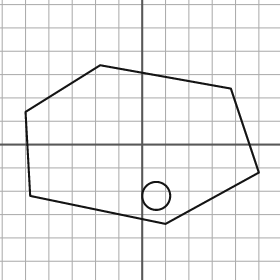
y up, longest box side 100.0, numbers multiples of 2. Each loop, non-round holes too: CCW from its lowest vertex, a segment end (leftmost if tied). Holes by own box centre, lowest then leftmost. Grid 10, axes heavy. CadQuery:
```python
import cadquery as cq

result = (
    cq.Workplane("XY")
    .moveTo(10.0, -34.0)
    .lineTo(50.0, -12.0)
    .lineTo(38.0, 24.0)
    .lineTo(-18.0, 34.0)
    .lineTo(-50.0, 14.0)
    .lineTo(-48.0, -22.0)
    .close()
    .moveTo(6.0, -22.0)
    .circle(6.0)
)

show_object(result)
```